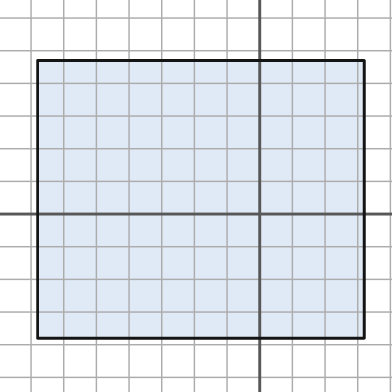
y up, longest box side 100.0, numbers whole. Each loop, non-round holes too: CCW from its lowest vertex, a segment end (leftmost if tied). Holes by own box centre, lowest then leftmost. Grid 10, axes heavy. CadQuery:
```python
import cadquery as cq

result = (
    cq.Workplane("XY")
    .moveTo(-68.0, -38.0)
    .lineTo(32.0, -38.0)
    .lineTo(32.0, 47.0)
    .lineTo(-68.0, 47.0)
    .close()
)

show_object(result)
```